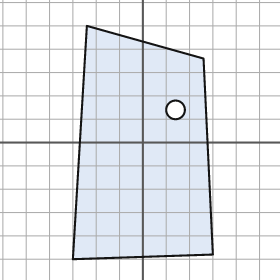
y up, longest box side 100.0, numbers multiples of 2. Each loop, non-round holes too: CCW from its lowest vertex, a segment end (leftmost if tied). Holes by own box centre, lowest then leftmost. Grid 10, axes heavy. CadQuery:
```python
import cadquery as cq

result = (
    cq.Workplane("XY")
    .moveTo(-30.0, -50.0)
    .lineTo(30.0, -48.0)
    .lineTo(26.0, 36.0)
    .lineTo(-24.0, 50.0)
    .close()
    .moveTo(14.0, 14.0)
    .circle(4.0)
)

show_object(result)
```